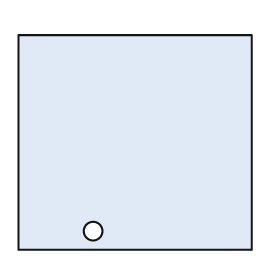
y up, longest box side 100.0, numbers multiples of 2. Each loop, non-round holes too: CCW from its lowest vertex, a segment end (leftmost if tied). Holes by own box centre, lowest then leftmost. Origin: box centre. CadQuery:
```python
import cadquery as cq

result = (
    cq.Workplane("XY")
    .moveTo(-50.0, -46.0)
    .lineTo(50.0, -46.0)
    .lineTo(50.0, 46.0)
    .lineTo(-50.0, 46.0)
    .close()
    .moveTo(-18.0, -38.0)
    .circle(4.0)
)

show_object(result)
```